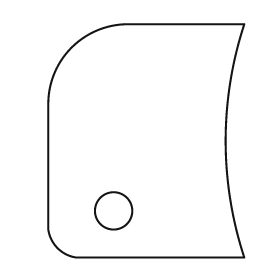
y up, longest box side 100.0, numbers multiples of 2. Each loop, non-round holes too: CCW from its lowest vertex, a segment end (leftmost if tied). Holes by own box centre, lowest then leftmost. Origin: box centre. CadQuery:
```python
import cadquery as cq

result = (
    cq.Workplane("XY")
    .moveTo(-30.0, -50.0)
    .lineTo(42.0, -50.0)
    .threePointArc((34.0, 0.0), (42.0, 50.0))
    .lineTo(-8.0, 50.0)
    .threePointArc((-32.0, 40.0), (-42.0, 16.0))
    .lineTo(-42.0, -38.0)
    .threePointArc((-38.0, -46.0), (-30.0, -50.0))
    .close()
    .moveTo(-14.0, -30.0)
    .circle(8.0)
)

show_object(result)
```